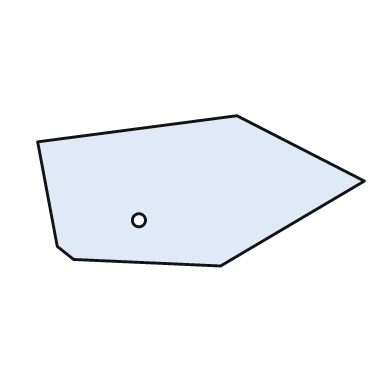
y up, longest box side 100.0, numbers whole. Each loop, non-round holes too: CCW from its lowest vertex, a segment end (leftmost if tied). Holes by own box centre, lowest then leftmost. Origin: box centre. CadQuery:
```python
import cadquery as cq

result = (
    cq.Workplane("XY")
    .moveTo(6.0, -23.0)
    .lineTo(50.0, 3.0)
    .lineTo(11.0, 23.0)
    .lineTo(-50.0, 15.0)
    .lineTo(-44.0, -17.0)
    .lineTo(-39.0, -21.0)
    .close()
    .moveTo(-19.0, -9.0)
    .circle(2.0)
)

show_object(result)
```